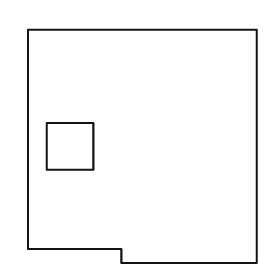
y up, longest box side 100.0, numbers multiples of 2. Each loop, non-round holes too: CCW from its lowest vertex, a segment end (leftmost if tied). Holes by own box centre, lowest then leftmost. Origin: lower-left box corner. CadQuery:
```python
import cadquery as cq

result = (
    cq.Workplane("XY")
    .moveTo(40.0, 0.0)
    .lineTo(98.0, 0.0)
    .lineTo(98.0, 100.0)
    .lineTo(0.0, 100.0)
    .lineTo(0.0, 6.0)
    .lineTo(40.0, 6.0)
    .close()
    .moveTo(8.0, 40.0)
    .lineTo(28.0, 40.0)
    .lineTo(28.0, 60.0)
    .lineTo(8.0, 60.0)
    .close()
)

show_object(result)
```